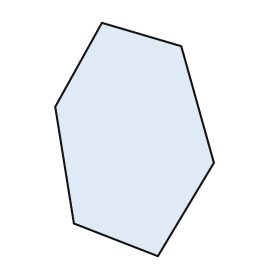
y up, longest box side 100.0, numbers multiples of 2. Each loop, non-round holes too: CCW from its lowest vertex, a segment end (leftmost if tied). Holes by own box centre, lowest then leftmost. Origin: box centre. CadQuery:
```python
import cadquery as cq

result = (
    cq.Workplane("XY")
    .moveTo(10.0, -50.0)
    .lineTo(34.0, -10.0)
    .lineTo(20.0, 40.0)
    .lineTo(-14.0, 50.0)
    .lineTo(-34.0, 14.0)
    .lineTo(-26.0, -36.0)
    .close()
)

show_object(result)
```